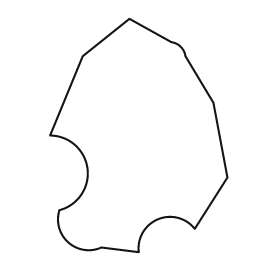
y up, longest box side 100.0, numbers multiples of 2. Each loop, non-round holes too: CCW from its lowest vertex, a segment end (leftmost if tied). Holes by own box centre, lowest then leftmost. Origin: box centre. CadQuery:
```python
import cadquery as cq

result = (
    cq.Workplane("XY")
    .moveTo(0.0, -50.0)
    .threePointArc((8.0, -36.0), (24.0, -40.0))
    .lineTo(38.0, -18.0)
    .lineTo(32.0, 14.0)
    .lineTo(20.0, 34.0)
    .threePointArc((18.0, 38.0), (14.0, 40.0))
    .lineTo(-4.0, 50.0)
    .lineTo(-24.0, 34.0)
    .lineTo(-38.0, 0.0)
    .threePointArc((-22.0, -14.0), (-34.0, -32.0))
    .threePointArc((-30.0, -46.0), (-16.0, -48.0))
    .close()
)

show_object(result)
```